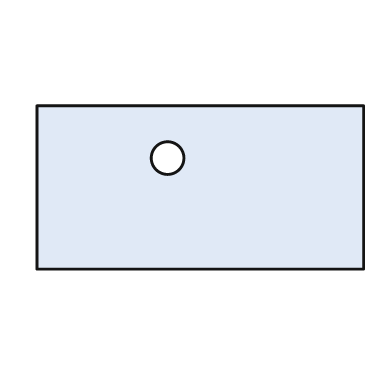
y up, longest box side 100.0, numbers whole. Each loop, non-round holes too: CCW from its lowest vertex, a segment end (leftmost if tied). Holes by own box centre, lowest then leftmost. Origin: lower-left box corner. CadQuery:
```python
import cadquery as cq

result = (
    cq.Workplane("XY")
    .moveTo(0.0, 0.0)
    .lineTo(100.0, 0.0)
    .lineTo(100.0, 50.0)
    .lineTo(0.0, 50.0)
    .close()
    .moveTo(40.0, 34.0)
    .circle(5.0)
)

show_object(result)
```